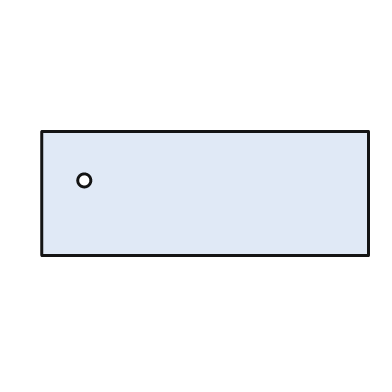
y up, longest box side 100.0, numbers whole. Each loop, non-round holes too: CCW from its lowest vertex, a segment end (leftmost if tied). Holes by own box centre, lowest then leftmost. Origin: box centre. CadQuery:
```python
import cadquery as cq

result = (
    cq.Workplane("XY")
    .moveTo(-50.0, -19.0)
    .lineTo(50.0, -19.0)
    .lineTo(50.0, 19.0)
    .lineTo(-50.0, 19.0)
    .close()
    .moveTo(-37.0, 4.0)
    .circle(2.0)
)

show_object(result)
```